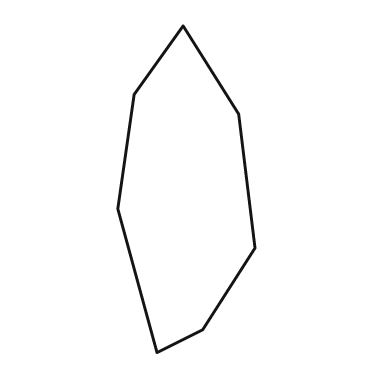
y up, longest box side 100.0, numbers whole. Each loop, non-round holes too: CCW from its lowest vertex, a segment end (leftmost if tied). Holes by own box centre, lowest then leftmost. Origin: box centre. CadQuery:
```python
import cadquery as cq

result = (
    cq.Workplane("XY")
    .moveTo(-9.0, -50.0)
    .lineTo(5.0, -43.0)
    .lineTo(21.0, -18.0)
    .lineTo(16.0, 23.0)
    .lineTo(-1.0, 50.0)
    .lineTo(-16.0, 29.0)
    .lineTo(-21.0, -6.0)
    .close()
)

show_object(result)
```